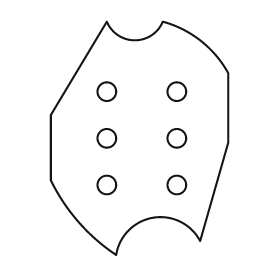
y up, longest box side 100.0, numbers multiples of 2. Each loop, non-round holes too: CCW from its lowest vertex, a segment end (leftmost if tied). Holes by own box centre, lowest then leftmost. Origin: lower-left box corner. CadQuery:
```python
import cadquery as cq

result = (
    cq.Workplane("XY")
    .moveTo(28.0, 0.0)
    .threePointArc((44.0, 16.0), (64.0, 6.0))
    .lineTo(76.0, 48.0)
    .lineTo(76.0, 78.0)
    .threePointArc((64.0, 92.0), (48.0, 100.0))
    .threePointArc((36.0, 92.0), (24.0, 100.0))
    .lineTo(0.0, 60.0)
    .lineTo(0.0, 32.0)
    .threePointArc((12.0, 14.0), (28.0, 0.0))
    .close()
    .moveTo(24.0, 30.0)
    .circle(4.0)
    .moveTo(54.0, 30.0)
    .circle(4.0)
    .moveTo(24.0, 50.0)
    .circle(4.0)
    .moveTo(54.0, 50.0)
    .circle(4.0)
    .moveTo(24.0, 70.0)
    .circle(4.0)
    .moveTo(54.0, 70.0)
    .circle(4.0)
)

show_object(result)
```